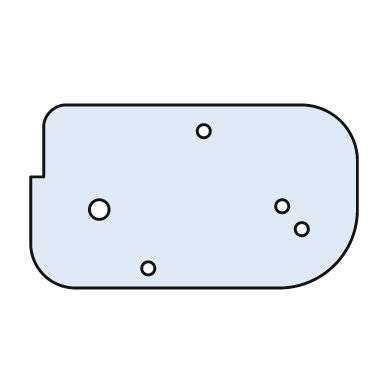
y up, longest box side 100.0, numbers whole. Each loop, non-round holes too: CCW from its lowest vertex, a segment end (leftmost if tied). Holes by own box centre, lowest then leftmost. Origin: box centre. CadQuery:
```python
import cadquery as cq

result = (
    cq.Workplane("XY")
    .moveTo(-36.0, -28.0)
    .lineTo(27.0, -28.0)
    .threePointArc((43.0, -21.0), (50.0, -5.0))
    .lineTo(50.0, 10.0)
    .threePointArc((45.0, 23.0), (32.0, 28.0))
    .lineTo(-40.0, 28.0)
    .threePointArc((-44.0, 26.0), (-46.0, 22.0))
    .lineTo(-46.0, 6.0)
    .lineTo(-50.0, 6.0)
    .lineTo(-50.0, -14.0)
    .threePointArc((-46.0, -24.0), (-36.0, -28.0))
    .close()
    .moveTo(-14.0, -22.0)
    .circle(2.0)
    .moveTo(33.0, -10.0)
    .circle(2.0)
    .moveTo(-29.0, -4.0)
    .circle(3.0)
    .moveTo(27.0, -3.0)
    .circle(2.0)
    .moveTo(3.0, 20.0)
    .circle(2.0)
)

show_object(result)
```